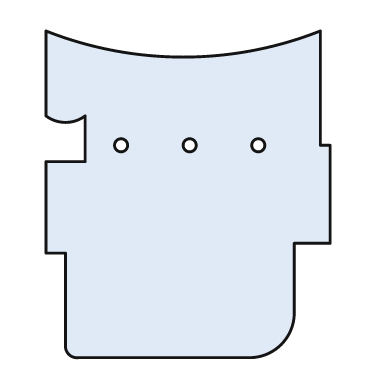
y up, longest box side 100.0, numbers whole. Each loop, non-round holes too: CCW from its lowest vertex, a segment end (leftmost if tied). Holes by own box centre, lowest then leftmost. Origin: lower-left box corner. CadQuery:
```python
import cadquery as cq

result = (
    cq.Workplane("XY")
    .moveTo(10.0, 0.0)
    .lineTo(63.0, 0.0)
    .threePointArc((72.0, 4.0), (76.0, 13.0))
    .lineTo(76.0, 35.0)
    .lineTo(87.0, 35.0)
    .lineTo(87.0, 65.0)
    .lineTo(84.0, 65.0)
    .lineTo(84.0, 100.0)
    .threePointArc((42.0, 92.0), (0.0, 100.0))
    .lineTo(0.0, 74.0)
    .threePointArc((6.0, 72.0), (12.0, 74.0))
    .lineTo(12.0, 60.0)
    .lineTo(0.0, 60.0)
    .lineTo(0.0, 32.0)
    .lineTo(6.0, 32.0)
    .lineTo(6.0, 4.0)
    .threePointArc((7.0, 1.0), (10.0, 0.0))
    .close()
    .moveTo(23.0, 65.0)
    .circle(2.0)
    .moveTo(44.0, 65.0)
    .circle(2.0)
    .moveTo(65.0, 65.0)
    .circle(2.0)
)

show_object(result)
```